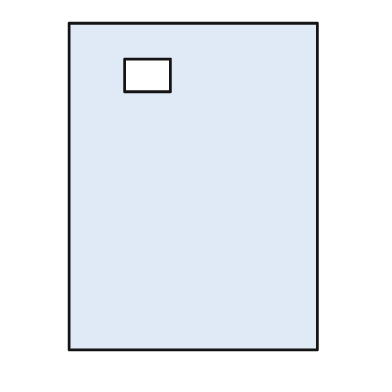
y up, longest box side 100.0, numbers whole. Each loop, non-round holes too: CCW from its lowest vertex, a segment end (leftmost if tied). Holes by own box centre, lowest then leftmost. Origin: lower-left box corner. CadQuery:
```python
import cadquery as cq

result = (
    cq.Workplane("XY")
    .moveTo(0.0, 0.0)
    .lineTo(76.0, 0.0)
    .lineTo(76.0, 100.0)
    .lineTo(0.0, 100.0)
    .close()
    .moveTo(17.0, 79.0)
    .lineTo(31.0, 79.0)
    .lineTo(31.0, 89.0)
    .lineTo(17.0, 89.0)
    .close()
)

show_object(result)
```